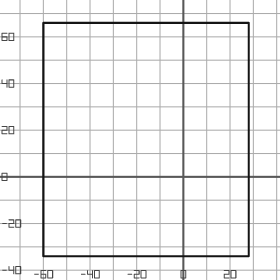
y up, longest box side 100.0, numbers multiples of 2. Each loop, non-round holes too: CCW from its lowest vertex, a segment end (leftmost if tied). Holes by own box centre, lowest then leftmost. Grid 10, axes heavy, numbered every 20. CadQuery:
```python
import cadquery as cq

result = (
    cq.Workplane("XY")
    .moveTo(-60.0, -34.0)
    .lineTo(28.0, -34.0)
    .lineTo(28.0, 66.0)
    .lineTo(-60.0, 66.0)
    .close()
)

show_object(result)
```